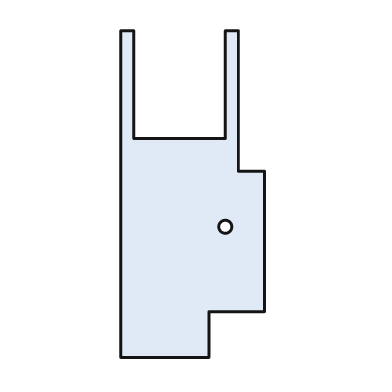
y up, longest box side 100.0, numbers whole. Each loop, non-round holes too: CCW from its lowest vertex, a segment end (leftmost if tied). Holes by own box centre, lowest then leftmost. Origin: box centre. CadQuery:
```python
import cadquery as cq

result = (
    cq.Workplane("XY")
    .moveTo(-22.0, -50.0)
    .lineTo(5.0, -50.0)
    .lineTo(5.0, -36.0)
    .lineTo(22.0, -36.0)
    .lineTo(22.0, 7.0)
    .lineTo(14.0, 7.0)
    .lineTo(14.0, 50.0)
    .lineTo(10.0, 50.0)
    .lineTo(10.0, 17.0)
    .lineTo(-18.0, 17.0)
    .lineTo(-18.0, 50.0)
    .lineTo(-22.0, 50.0)
    .close()
    .moveTo(10.0, -10.0)
    .circle(2.0)
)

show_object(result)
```